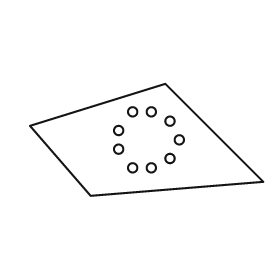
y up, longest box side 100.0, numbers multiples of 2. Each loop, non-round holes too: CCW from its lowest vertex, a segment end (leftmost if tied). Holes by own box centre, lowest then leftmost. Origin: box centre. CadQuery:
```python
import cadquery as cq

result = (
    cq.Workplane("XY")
    .moveTo(-24.0, -24.0)
    .lineTo(50.0, -18.0)
    .lineTo(8.0, 24.0)
    .lineTo(-50.0, 6.0)
    .close()
    .moveTo(-6.0, -12.0)
    .circle(2.0)
    .moveTo(2.0, -12.0)
    .circle(2.0)
    .moveTo(10.0, -8.0)
    .circle(2.0)
    .moveTo(-12.0, -4.0)
    .circle(2.0)
    .moveTo(14.0, 0.0)
    .circle(2.0)
    .moveTo(-12.0, 4.0)
    .circle(2.0)
    .moveTo(10.0, 8.0)
    .circle(2.0)
    .moveTo(-6.0, 12.0)
    .circle(2.0)
    .moveTo(2.0, 12.0)
    .circle(2.0)
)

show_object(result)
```